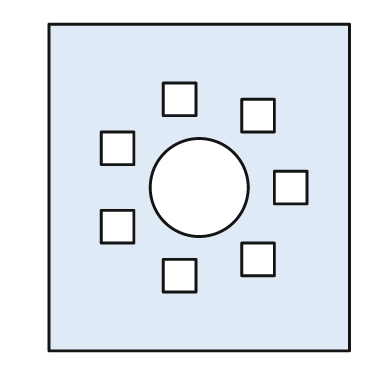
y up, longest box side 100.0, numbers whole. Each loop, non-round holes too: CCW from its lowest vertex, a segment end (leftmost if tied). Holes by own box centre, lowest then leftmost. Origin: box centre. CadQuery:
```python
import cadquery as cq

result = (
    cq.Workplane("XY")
    .moveTo(-46.0, -50.0)
    .lineTo(46.0, -50.0)
    .lineTo(46.0, 50.0)
    .lineTo(-46.0, 50.0)
    .close()
    .moveTo(-11.0, -32.0)
    .lineTo(-1.0, -32.0)
    .lineTo(-1.0, -22.0)
    .lineTo(-11.0, -22.0)
    .close()
    .moveTo(13.0, -27.0)
    .lineTo(23.0, -27.0)
    .lineTo(23.0, -17.0)
    .lineTo(13.0, -17.0)
    .close()
    .moveTo(-30.0, -17.0)
    .lineTo(-20.0, -17.0)
    .lineTo(-20.0, -7.0)
    .lineTo(-30.0, -7.0)
    .close()
    .moveTo(0.0, 0.0)
    .circle(15.0)
    .moveTo(23.0, -5.0)
    .lineTo(33.0, -5.0)
    .lineTo(33.0, 5.0)
    .lineTo(23.0, 5.0)
    .close()
    .moveTo(-30.0, 7.0)
    .lineTo(-20.0, 7.0)
    .lineTo(-20.0, 17.0)
    .lineTo(-30.0, 17.0)
    .close()
    .moveTo(13.0, 17.0)
    .lineTo(23.0, 17.0)
    .lineTo(23.0, 27.0)
    .lineTo(13.0, 27.0)
    .close()
    .moveTo(-11.0, 22.0)
    .lineTo(-1.0, 22.0)
    .lineTo(-1.0, 32.0)
    .lineTo(-11.0, 32.0)
    .close()
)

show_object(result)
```